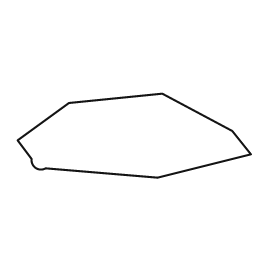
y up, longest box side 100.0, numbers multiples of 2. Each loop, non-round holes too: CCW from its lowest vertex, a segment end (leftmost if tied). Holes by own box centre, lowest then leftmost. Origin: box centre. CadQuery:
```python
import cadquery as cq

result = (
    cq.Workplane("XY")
    .moveTo(10.0, -18.0)
    .lineTo(50.0, -8.0)
    .lineTo(42.0, 2.0)
    .lineTo(12.0, 18.0)
    .lineTo(-28.0, 14.0)
    .lineTo(-50.0, -2.0)
    .lineTo(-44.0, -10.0)
    .threePointArc((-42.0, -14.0), (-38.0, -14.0))
    .close()
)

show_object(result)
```